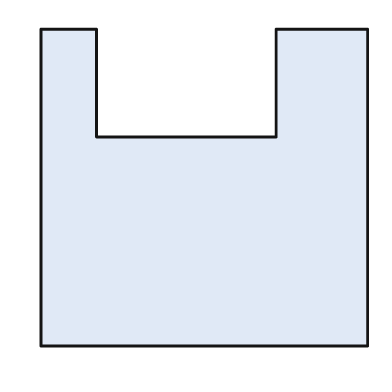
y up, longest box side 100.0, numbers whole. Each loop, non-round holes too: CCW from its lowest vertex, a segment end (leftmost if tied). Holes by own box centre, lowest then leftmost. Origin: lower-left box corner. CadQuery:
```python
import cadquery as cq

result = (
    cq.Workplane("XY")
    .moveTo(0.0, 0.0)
    .lineTo(100.0, 0.0)
    .lineTo(100.0, 97.0)
    .lineTo(72.0, 97.0)
    .lineTo(72.0, 64.0)
    .lineTo(17.0, 64.0)
    .lineTo(17.0, 97.0)
    .lineTo(0.0, 97.0)
    .close()
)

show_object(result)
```